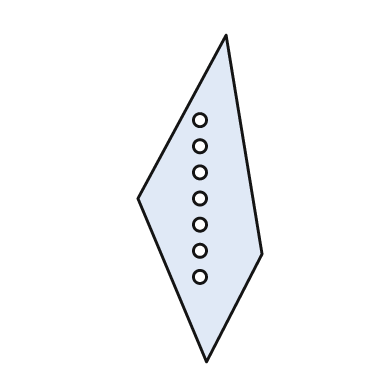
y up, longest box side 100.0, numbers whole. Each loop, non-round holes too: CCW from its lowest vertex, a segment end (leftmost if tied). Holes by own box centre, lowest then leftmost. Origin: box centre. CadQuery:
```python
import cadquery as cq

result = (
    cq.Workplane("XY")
    .moveTo(2.0, -50.0)
    .lineTo(19.0, -17.0)
    .lineTo(8.0, 50.0)
    .lineTo(-19.0, 0.0)
    .close()
    .moveTo(0.0, -24.0)
    .circle(2.0)
    .moveTo(0.0, -16.0)
    .circle(2.0)
    .moveTo(0.0, -8.0)
    .circle(2.0)
    .moveTo(0.0, 0.0)
    .circle(2.0)
    .moveTo(0.0, 8.0)
    .circle(2.0)
    .moveTo(0.0, 16.0)
    .circle(2.0)
    .moveTo(0.0, 24.0)
    .circle(2.0)
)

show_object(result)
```